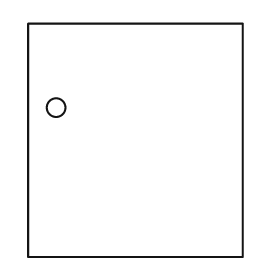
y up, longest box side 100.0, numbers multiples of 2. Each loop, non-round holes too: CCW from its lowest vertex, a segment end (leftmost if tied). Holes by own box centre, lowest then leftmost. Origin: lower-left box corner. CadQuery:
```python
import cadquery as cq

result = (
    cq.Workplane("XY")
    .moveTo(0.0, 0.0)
    .lineTo(92.0, 0.0)
    .lineTo(92.0, 100.0)
    .lineTo(0.0, 100.0)
    .close()
    .moveTo(12.0, 64.0)
    .circle(4.0)
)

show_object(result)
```